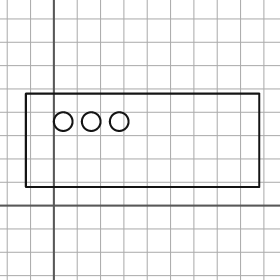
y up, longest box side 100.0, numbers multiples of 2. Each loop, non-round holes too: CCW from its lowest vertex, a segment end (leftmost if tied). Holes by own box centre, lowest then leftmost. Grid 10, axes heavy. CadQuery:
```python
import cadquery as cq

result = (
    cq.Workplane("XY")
    .moveTo(-12.0, 8.0)
    .lineTo(88.0, 8.0)
    .lineTo(88.0, 48.0)
    .lineTo(-12.0, 48.0)
    .close()
    .moveTo(4.0, 36.0)
    .circle(4.0)
    .moveTo(16.0, 36.0)
    .circle(4.0)
    .moveTo(28.0, 36.0)
    .circle(4.0)
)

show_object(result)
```